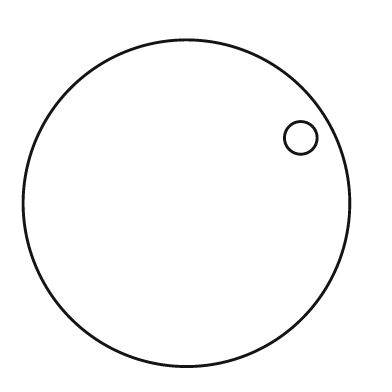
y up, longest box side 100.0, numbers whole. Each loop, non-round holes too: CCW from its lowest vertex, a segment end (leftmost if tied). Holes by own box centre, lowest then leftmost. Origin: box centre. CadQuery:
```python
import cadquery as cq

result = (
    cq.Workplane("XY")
    .moveTo(0.0, 0.0)
    .circle(50.0)
    .moveTo(35.0, 20.0)
    .circle(5.0)
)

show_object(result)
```